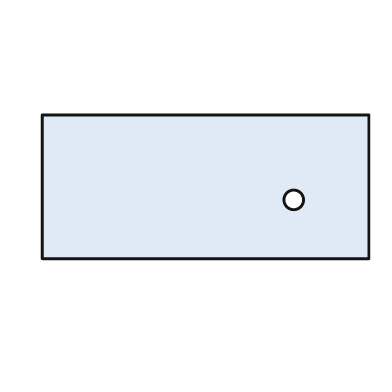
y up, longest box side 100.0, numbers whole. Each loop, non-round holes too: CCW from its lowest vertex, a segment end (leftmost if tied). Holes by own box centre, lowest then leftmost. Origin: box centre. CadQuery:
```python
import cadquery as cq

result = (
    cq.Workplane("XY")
    .moveTo(-50.0, -22.0)
    .lineTo(50.0, -22.0)
    .lineTo(50.0, 22.0)
    .lineTo(-50.0, 22.0)
    .close()
    .moveTo(27.0, -4.0)
    .circle(3.0)
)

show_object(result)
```